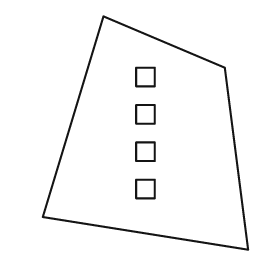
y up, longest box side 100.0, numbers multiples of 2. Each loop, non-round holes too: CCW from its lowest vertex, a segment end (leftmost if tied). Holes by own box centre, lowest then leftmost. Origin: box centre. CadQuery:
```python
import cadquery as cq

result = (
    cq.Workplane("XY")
    .moveTo(44.0, -50.0)
    .lineTo(34.0, 28.0)
    .lineTo(-18.0, 50.0)
    .lineTo(-44.0, -36.0)
    .close()
    .moveTo(-4.0, -28.0)
    .lineTo(4.0, -28.0)
    .lineTo(4.0, -20.0)
    .lineTo(-4.0, -20.0)
    .close()
    .moveTo(-4.0, -12.0)
    .lineTo(4.0, -12.0)
    .lineTo(4.0, -4.0)
    .lineTo(-4.0, -4.0)
    .close()
    .moveTo(-4.0, 4.0)
    .lineTo(4.0, 4.0)
    .lineTo(4.0, 12.0)
    .lineTo(-4.0, 12.0)
    .close()
    .moveTo(-4.0, 20.0)
    .lineTo(4.0, 20.0)
    .lineTo(4.0, 28.0)
    .lineTo(-4.0, 28.0)
    .close()
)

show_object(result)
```